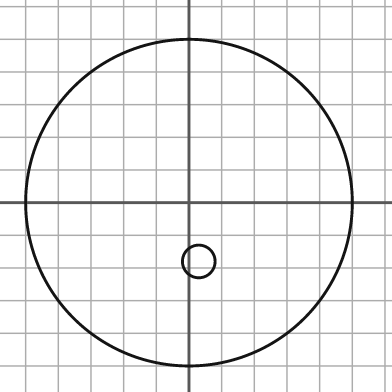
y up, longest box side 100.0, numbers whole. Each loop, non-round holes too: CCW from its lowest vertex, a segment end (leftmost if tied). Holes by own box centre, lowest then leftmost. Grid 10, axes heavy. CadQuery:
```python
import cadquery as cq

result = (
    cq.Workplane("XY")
    .moveTo(0.0, 0.0)
    .circle(50.0)
    .moveTo(3.0, -18.0)
    .circle(5.0)
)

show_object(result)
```